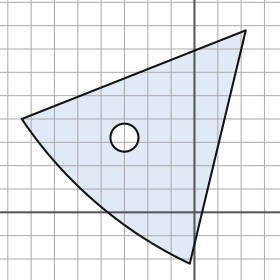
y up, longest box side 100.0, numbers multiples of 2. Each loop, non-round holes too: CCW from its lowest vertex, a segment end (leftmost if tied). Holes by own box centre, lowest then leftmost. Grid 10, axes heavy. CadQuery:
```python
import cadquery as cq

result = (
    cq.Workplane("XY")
    .moveTo(-2.0, -22.0)
    .lineTo(22.0, 78.0)
    .lineTo(-74.0, 40.0)
    .threePointArc((-42.0, 4.0), (-2.0, -22.0))
    .close()
    .moveTo(-30.0, 32.0)
    .circle(6.0)
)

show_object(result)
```